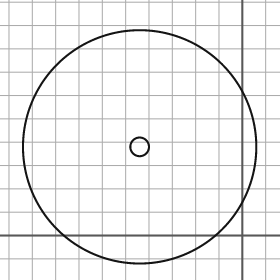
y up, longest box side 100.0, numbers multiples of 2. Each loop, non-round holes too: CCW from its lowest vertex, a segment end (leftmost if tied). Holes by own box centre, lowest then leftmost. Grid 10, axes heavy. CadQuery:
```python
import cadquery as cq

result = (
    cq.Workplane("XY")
    .moveTo(-44.0, 38.0)
    .circle(50.0)
    .moveTo(-44.0, 38.0)
    .circle(4.0)
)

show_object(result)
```